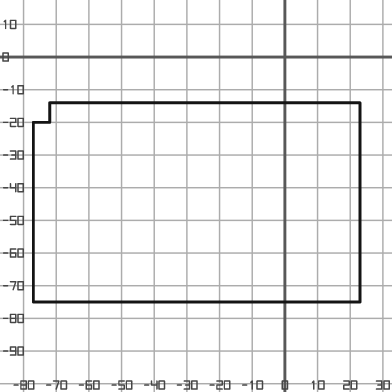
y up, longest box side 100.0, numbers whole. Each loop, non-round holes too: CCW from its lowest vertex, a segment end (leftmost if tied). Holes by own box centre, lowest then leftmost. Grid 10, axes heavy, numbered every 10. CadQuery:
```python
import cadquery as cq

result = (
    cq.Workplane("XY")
    .moveTo(-77.0, -75.0)
    .lineTo(23.0, -75.0)
    .lineTo(23.0, -14.0)
    .lineTo(-72.0, -14.0)
    .lineTo(-72.0, -20.0)
    .lineTo(-77.0, -20.0)
    .close()
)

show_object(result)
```